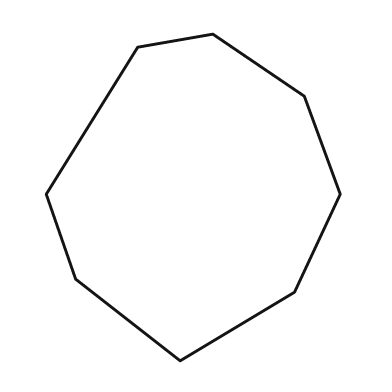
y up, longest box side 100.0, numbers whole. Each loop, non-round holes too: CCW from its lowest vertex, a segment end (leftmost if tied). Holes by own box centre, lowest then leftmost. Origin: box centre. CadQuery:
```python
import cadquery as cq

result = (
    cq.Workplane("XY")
    .moveTo(-4.0, -50.0)
    .lineTo(31.0, -29.0)
    .lineTo(45.0, 1.0)
    .lineTo(34.0, 31.0)
    .lineTo(6.0, 50.0)
    .lineTo(-17.0, 46.0)
    .lineTo(-45.0, 1.0)
    .lineTo(-36.0, -25.0)
    .close()
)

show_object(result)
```